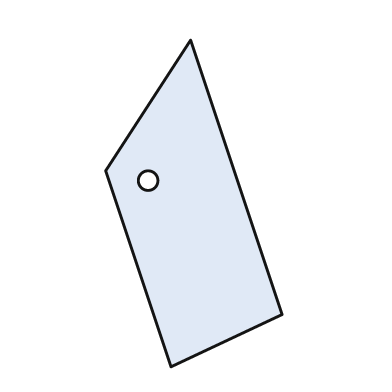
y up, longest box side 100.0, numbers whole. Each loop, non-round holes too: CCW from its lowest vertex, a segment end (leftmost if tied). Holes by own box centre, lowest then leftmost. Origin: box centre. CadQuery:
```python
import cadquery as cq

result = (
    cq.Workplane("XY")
    .moveTo(-7.0, -50.0)
    .lineTo(27.0, -34.0)
    .lineTo(-1.0, 50.0)
    .lineTo(-27.0, 10.0)
    .close()
    .moveTo(-14.0, 7.0)
    .circle(3.0)
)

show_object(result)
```